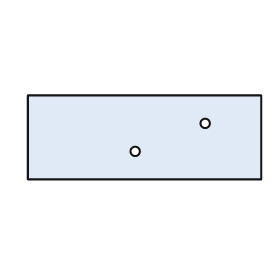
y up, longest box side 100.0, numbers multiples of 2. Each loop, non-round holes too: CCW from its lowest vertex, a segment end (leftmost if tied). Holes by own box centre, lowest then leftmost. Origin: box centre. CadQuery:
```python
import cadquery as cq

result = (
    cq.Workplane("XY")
    .moveTo(-50.0, -18.0)
    .lineTo(50.0, -18.0)
    .lineTo(50.0, 18.0)
    .lineTo(-50.0, 18.0)
    .close()
    .moveTo(-4.0, -6.0)
    .circle(2.0)
    .moveTo(26.0, 6.0)
    .circle(2.0)
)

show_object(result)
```